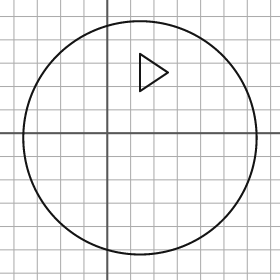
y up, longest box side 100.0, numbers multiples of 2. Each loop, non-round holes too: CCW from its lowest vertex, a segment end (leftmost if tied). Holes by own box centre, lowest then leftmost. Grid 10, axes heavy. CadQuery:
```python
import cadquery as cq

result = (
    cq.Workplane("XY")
    .moveTo(14.0, -2.0)
    .circle(50.0)
    .moveTo(14.0, 18.0)
    .lineTo(26.0, 26.0)
    .lineTo(14.0, 34.0)
    .close()
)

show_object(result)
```